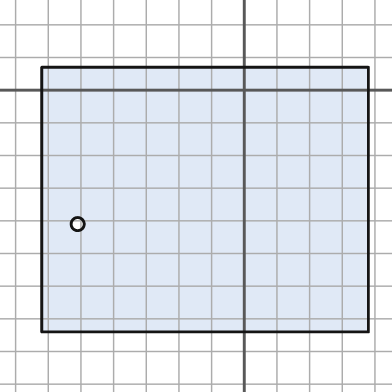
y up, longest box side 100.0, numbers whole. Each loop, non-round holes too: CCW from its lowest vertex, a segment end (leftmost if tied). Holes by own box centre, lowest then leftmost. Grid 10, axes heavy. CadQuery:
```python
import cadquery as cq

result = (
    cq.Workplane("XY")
    .moveTo(-62.0, -74.0)
    .lineTo(38.0, -74.0)
    .lineTo(38.0, 7.0)
    .lineTo(-62.0, 7.0)
    .close()
    .moveTo(-51.0, -41.0)
    .circle(2.0)
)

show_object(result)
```